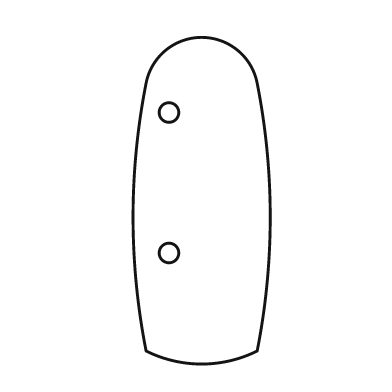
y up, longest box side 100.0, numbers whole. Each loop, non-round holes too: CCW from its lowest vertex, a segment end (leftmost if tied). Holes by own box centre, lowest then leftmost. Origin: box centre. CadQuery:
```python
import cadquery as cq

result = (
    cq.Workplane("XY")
    .moveTo(-17.0, -46.0)
    .threePointArc((0.0, -50.0), (17.0, -46.0))
    .threePointArc((21.0, -5.0), (17.0, 36.0))
    .threePointArc((0.0, 50.0), (-17.0, 36.0))
    .threePointArc((-21.0, -5.0), (-17.0, -46.0))
    .close()
    .moveTo(-10.0, -16.0)
    .circle(3.0)
    .moveTo(-10.0, 27.0)
    .circle(3.0)
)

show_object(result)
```